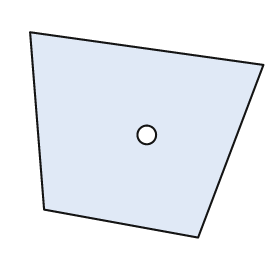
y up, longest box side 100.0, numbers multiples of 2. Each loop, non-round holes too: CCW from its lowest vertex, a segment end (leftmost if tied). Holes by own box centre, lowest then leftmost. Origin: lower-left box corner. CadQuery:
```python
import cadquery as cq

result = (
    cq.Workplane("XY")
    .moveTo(72.0, 0.0)
    .lineTo(100.0, 74.0)
    .lineTo(0.0, 88.0)
    .lineTo(6.0, 12.0)
    .close()
    .moveTo(50.0, 44.0)
    .circle(4.0)
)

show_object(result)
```